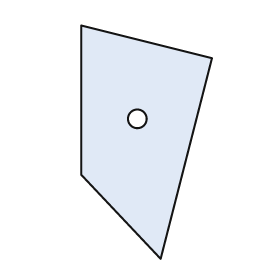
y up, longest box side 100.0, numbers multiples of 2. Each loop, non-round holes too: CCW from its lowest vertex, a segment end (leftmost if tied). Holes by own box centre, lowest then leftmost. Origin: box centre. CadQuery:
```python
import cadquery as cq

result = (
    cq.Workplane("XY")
    .moveTo(6.0, -50.0)
    .lineTo(28.0, 36.0)
    .lineTo(-28.0, 50.0)
    .lineTo(-28.0, -14.0)
    .close()
    .moveTo(-4.0, 10.0)
    .circle(4.0)
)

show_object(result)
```